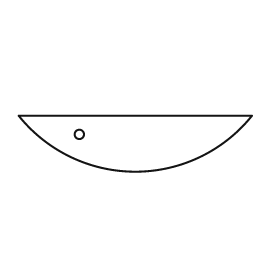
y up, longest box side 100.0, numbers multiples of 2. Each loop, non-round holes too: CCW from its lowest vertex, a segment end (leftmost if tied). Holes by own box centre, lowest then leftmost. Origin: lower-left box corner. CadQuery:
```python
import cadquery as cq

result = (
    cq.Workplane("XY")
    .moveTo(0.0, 24.0)
    .threePointArc((50.0, 0.0), (100.0, 24.0))
    .close()
    .moveTo(26.0, 16.0)
    .circle(2.0)
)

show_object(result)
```